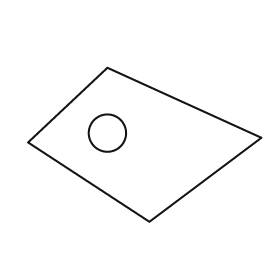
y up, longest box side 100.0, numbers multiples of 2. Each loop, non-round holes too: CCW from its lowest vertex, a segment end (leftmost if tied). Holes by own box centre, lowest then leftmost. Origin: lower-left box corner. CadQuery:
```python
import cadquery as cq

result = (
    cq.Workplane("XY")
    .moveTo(52.0, 0.0)
    .lineTo(100.0, 36.0)
    .lineTo(34.0, 66.0)
    .lineTo(0.0, 34.0)
    .close()
    .moveTo(34.0, 38.0)
    .circle(8.0)
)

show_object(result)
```